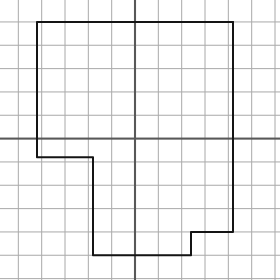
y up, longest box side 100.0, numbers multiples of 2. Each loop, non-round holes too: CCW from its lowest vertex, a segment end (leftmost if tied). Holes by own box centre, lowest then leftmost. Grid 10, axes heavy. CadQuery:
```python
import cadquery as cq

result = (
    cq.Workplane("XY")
    .moveTo(-18.0, -50.0)
    .lineTo(24.0, -50.0)
    .lineTo(24.0, -40.0)
    .lineTo(42.0, -40.0)
    .lineTo(42.0, 50.0)
    .lineTo(-42.0, 50.0)
    .lineTo(-42.0, -8.0)
    .lineTo(-18.0, -8.0)
    .close()
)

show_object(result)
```